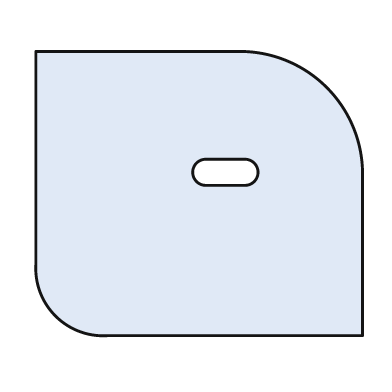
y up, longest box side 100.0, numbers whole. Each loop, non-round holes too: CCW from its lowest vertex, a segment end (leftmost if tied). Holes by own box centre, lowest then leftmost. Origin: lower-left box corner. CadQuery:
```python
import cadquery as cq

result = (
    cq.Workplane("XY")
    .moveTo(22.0, 0.0)
    .lineTo(100.0, 0.0)
    .lineTo(100.0, 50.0)
    .threePointArc((89.0, 76.0), (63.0, 87.0))
    .lineTo(0.0, 87.0)
    .lineTo(0.0, 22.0)
    .threePointArc((6.0, 6.0), (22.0, 0.0))
    .close()
    .moveTo(52.0, 46.0)
    .lineTo(64.0, 46.0)
    .threePointArc((68.0, 50.0), (64.0, 54.0))
    .lineTo(52.0, 54.0)
    .threePointArc((48.0, 50.0), (52.0, 46.0))
    .close()
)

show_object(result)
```